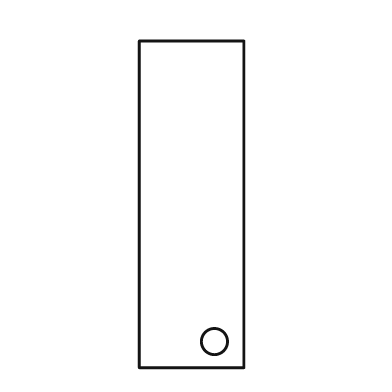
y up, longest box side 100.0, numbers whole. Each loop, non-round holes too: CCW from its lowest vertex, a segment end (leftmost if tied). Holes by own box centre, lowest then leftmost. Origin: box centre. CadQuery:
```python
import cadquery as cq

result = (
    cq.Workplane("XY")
    .moveTo(-16.0, -50.0)
    .lineTo(16.0, -50.0)
    .lineTo(16.0, 50.0)
    .lineTo(-16.0, 50.0)
    .close()
    .moveTo(7.0, -42.0)
    .circle(4.0)
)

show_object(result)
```